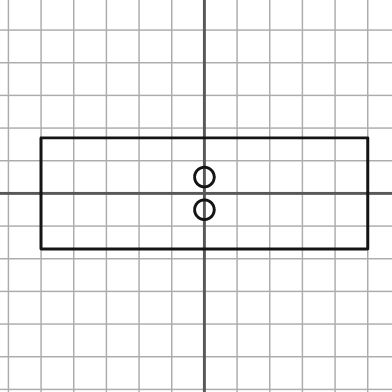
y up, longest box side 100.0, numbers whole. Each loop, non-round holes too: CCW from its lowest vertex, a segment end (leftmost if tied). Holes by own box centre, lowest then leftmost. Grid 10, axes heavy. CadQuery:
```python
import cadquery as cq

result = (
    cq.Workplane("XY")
    .moveTo(-50.0, -17.0)
    .lineTo(50.0, -17.0)
    .lineTo(50.0, 17.0)
    .lineTo(-50.0, 17.0)
    .close()
    .moveTo(0.0, -5.0)
    .circle(3.0)
    .moveTo(0.0, 5.0)
    .circle(3.0)
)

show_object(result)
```